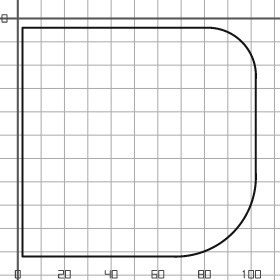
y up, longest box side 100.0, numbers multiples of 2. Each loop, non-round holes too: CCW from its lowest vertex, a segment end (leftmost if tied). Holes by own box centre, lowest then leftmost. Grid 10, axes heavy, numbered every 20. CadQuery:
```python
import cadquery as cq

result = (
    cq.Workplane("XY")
    .moveTo(2.0, -102.0)
    .lineTo(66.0, -102.0)
    .threePointArc((92.0, -92.0), (102.0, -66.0))
    .lineTo(102.0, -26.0)
    .threePointArc((96.0, -10.0), (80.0, -4.0))
    .lineTo(2.0, -4.0)
    .close()
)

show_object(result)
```